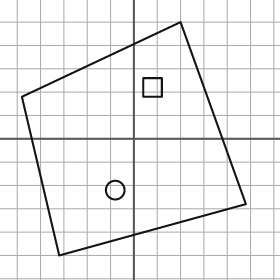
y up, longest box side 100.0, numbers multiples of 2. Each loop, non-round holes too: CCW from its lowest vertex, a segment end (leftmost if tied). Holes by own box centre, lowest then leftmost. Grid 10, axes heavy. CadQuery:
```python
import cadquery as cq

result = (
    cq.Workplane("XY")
    .moveTo(-32.0, -50.0)
    .lineTo(48.0, -28.0)
    .lineTo(20.0, 50.0)
    .lineTo(-48.0, 18.0)
    .close()
    .moveTo(-8.0, -22.0)
    .circle(4.0)
    .moveTo(4.0, 18.0)
    .lineTo(12.0, 18.0)
    .lineTo(12.0, 26.0)
    .lineTo(4.0, 26.0)
    .close()
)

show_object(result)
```